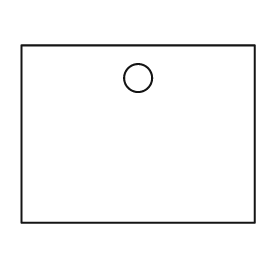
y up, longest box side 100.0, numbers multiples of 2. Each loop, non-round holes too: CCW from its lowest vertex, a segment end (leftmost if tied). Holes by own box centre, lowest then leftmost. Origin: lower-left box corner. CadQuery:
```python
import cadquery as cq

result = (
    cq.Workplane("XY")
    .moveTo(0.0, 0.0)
    .lineTo(100.0, 0.0)
    .lineTo(100.0, 76.0)
    .lineTo(0.0, 76.0)
    .close()
    .moveTo(50.0, 62.0)
    .circle(6.0)
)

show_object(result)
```